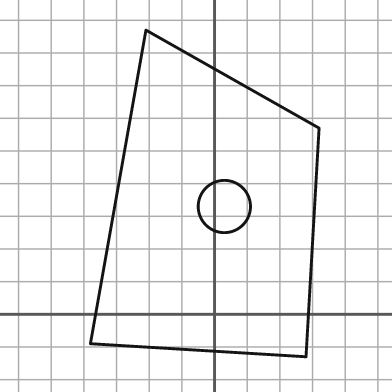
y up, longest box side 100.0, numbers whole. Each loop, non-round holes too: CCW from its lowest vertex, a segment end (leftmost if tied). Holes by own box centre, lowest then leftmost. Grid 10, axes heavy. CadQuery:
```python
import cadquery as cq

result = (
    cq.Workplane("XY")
    .moveTo(28.0, -13.0)
    .lineTo(32.0, 57.0)
    .lineTo(-21.0, 87.0)
    .lineTo(-38.0, -9.0)
    .close()
    .moveTo(3.0, 33.0)
    .circle(8.0)
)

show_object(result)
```